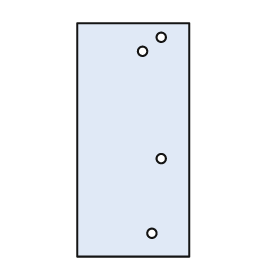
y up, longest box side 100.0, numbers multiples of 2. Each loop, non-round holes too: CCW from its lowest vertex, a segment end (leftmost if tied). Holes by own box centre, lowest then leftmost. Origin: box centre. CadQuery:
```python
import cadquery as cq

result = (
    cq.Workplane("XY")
    .moveTo(-24.0, -50.0)
    .lineTo(24.0, -50.0)
    .lineTo(24.0, 50.0)
    .lineTo(-24.0, 50.0)
    .close()
    .moveTo(8.0, -40.0)
    .circle(2.0)
    .moveTo(12.0, -8.0)
    .circle(2.0)
    .moveTo(4.0, 38.0)
    .circle(2.0)
    .moveTo(12.0, 44.0)
    .circle(2.0)
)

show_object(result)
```